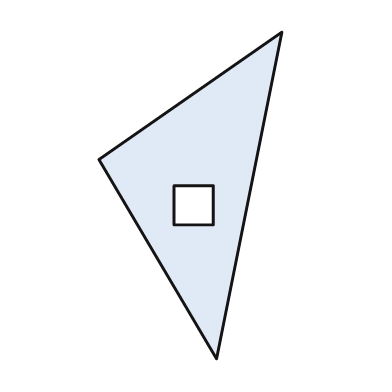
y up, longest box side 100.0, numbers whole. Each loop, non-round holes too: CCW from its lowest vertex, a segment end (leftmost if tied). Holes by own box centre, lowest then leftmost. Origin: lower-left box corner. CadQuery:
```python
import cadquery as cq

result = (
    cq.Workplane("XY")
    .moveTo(36.0, 0.0)
    .lineTo(56.0, 100.0)
    .lineTo(0.0, 61.0)
    .close()
    .moveTo(23.0, 41.0)
    .lineTo(35.0, 41.0)
    .lineTo(35.0, 53.0)
    .lineTo(23.0, 53.0)
    .close()
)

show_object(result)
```